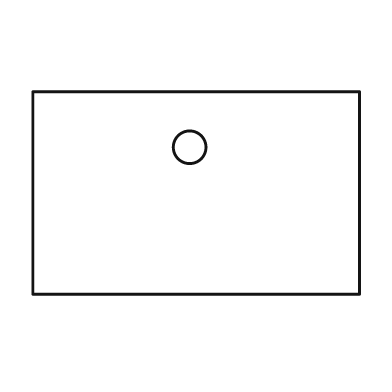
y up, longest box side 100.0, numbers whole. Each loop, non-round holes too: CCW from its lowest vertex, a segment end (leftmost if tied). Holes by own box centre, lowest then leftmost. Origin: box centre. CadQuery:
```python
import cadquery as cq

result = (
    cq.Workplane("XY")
    .moveTo(-50.0, -31.0)
    .lineTo(50.0, -31.0)
    .lineTo(50.0, 31.0)
    .lineTo(-50.0, 31.0)
    .close()
    .moveTo(-2.0, 14.0)
    .circle(5.0)
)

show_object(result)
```